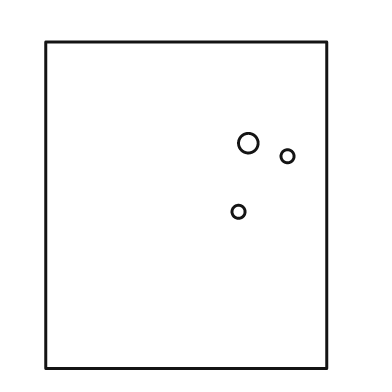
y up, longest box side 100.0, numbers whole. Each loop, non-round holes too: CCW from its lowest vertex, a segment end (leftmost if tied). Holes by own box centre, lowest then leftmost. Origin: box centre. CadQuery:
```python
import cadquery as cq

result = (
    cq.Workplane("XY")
    .moveTo(-43.0, -50.0)
    .lineTo(43.0, -50.0)
    .lineTo(43.0, 50.0)
    .lineTo(-43.0, 50.0)
    .close()
    .moveTo(16.0, -2.0)
    .circle(2.0)
    .moveTo(31.0, 15.0)
    .circle(2.0)
    .moveTo(19.0, 19.0)
    .circle(3.0)
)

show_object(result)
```